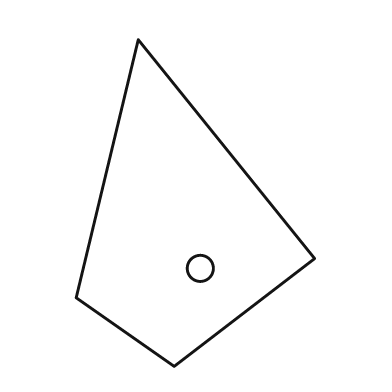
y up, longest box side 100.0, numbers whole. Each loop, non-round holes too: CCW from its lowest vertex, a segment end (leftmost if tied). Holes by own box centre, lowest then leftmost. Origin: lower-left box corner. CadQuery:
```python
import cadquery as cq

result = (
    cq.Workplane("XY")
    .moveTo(30.0, 0.0)
    .lineTo(73.0, 33.0)
    .lineTo(19.0, 100.0)
    .lineTo(0.0, 21.0)
    .close()
    .moveTo(38.0, 30.0)
    .circle(4.0)
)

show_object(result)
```